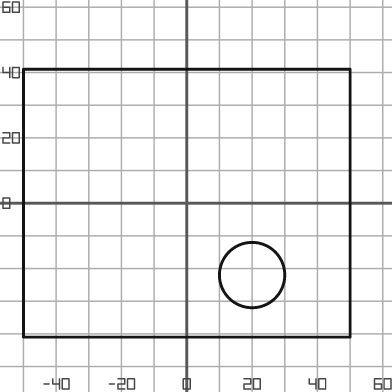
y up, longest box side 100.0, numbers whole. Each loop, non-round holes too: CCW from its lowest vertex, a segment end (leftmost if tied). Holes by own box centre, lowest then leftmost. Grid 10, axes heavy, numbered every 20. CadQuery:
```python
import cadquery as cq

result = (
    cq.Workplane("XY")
    .moveTo(-50.0, -41.0)
    .lineTo(50.0, -41.0)
    .lineTo(50.0, 41.0)
    .lineTo(-50.0, 41.0)
    .close()
    .moveTo(20.0, -22.0)
    .circle(10.0)
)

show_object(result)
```